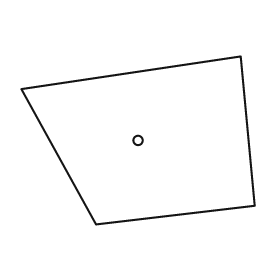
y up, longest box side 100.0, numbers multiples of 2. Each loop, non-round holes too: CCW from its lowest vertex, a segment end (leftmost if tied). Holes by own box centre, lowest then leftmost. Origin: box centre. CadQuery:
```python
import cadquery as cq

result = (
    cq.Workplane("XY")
    .moveTo(-18.0, -36.0)
    .lineTo(50.0, -28.0)
    .lineTo(44.0, 36.0)
    .lineTo(-50.0, 22.0)
    .close()
    .moveTo(0.0, 0.0)
    .circle(2.0)
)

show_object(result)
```